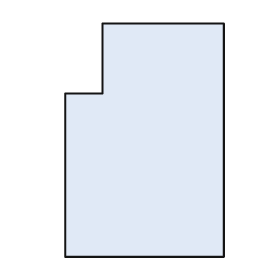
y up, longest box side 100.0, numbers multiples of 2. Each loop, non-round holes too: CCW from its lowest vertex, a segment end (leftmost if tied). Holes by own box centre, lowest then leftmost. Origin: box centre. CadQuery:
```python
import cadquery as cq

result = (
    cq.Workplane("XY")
    .moveTo(-34.0, -50.0)
    .lineTo(34.0, -50.0)
    .lineTo(34.0, 50.0)
    .lineTo(-18.0, 50.0)
    .lineTo(-18.0, 20.0)
    .lineTo(-34.0, 20.0)
    .close()
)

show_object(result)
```